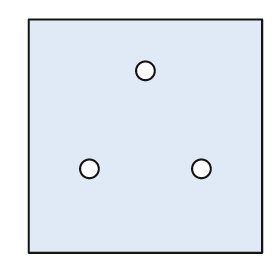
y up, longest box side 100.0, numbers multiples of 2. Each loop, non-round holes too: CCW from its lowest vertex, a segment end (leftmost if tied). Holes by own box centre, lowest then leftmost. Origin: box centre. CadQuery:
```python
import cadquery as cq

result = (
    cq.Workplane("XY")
    .moveTo(-50.0, -50.0)
    .lineTo(50.0, -50.0)
    .lineTo(50.0, 50.0)
    .lineTo(-50.0, 50.0)
    .close()
    .moveTo(-24.0, -14.0)
    .circle(4.0)
    .moveTo(24.0, -14.0)
    .circle(4.0)
    .moveTo(0.0, 28.0)
    .circle(4.0)
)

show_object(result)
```